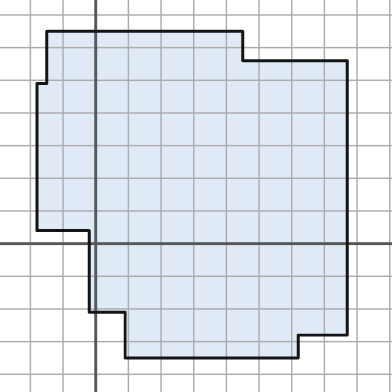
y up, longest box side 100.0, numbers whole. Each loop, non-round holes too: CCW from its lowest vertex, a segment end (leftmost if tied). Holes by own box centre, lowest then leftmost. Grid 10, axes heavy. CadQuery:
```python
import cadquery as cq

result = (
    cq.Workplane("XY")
    .moveTo(9.0, -35.0)
    .lineTo(62.0, -35.0)
    .lineTo(62.0, -28.0)
    .lineTo(77.0, -28.0)
    .lineTo(77.0, 56.0)
    .lineTo(45.0, 56.0)
    .lineTo(45.0, 65.0)
    .lineTo(-15.0, 65.0)
    .lineTo(-15.0, 49.0)
    .lineTo(-18.0, 49.0)
    .lineTo(-18.0, 4.0)
    .lineTo(-2.0, 4.0)
    .lineTo(-2.0, -21.0)
    .lineTo(9.0, -21.0)
    .close()
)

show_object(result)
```